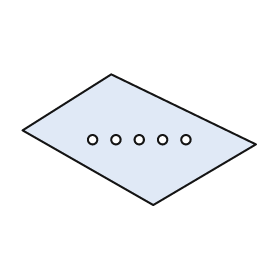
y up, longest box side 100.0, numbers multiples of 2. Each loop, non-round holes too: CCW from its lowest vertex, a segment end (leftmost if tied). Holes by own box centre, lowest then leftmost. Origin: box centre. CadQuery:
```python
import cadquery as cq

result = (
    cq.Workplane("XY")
    .moveTo(6.0, -28.0)
    .lineTo(50.0, -2.0)
    .lineTo(-12.0, 28.0)
    .lineTo(-50.0, 4.0)
    .close()
    .moveTo(-20.0, 0.0)
    .circle(2.0)
    .moveTo(-10.0, 0.0)
    .circle(2.0)
    .moveTo(0.0, 0.0)
    .circle(2.0)
    .moveTo(10.0, 0.0)
    .circle(2.0)
    .moveTo(20.0, 0.0)
    .circle(2.0)
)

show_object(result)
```